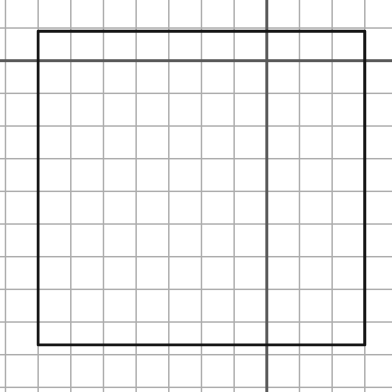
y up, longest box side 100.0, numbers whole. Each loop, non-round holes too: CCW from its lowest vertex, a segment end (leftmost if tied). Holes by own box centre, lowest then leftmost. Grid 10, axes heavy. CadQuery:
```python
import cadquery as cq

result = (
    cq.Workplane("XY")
    .moveTo(-70.0, -87.0)
    .lineTo(30.0, -87.0)
    .lineTo(30.0, 9.0)
    .lineTo(-70.0, 9.0)
    .close()
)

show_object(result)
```